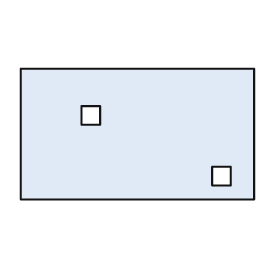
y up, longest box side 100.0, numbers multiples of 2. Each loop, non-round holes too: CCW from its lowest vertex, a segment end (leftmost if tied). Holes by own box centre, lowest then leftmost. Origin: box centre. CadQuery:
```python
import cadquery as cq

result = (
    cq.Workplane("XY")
    .moveTo(-50.0, -28.0)
    .lineTo(50.0, -28.0)
    .lineTo(50.0, 28.0)
    .lineTo(-50.0, 28.0)
    .close()
    .moveTo(32.0, -22.0)
    .lineTo(40.0, -22.0)
    .lineTo(40.0, -14.0)
    .lineTo(32.0, -14.0)
    .close()
    .moveTo(-24.0, 4.0)
    .lineTo(-16.0, 4.0)
    .lineTo(-16.0, 12.0)
    .lineTo(-24.0, 12.0)
    .close()
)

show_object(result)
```